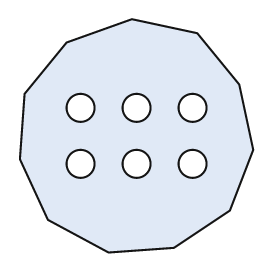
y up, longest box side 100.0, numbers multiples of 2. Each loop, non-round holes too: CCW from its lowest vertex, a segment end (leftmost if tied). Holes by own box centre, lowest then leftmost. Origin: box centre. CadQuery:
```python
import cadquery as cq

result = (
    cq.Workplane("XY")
    .moveTo(-12.0, -50.0)
    .lineTo(16.0, -48.0)
    .lineTo(40.0, -32.0)
    .lineTo(50.0, -6.0)
    .lineTo(44.0, 22.0)
    .lineTo(26.0, 44.0)
    .lineTo(-2.0, 50.0)
    .lineTo(-30.0, 40.0)
    .lineTo(-48.0, 18.0)
    .lineTo(-50.0, -10.0)
    .lineTo(-38.0, -36.0)
    .close()
    .moveTo(-24.0, -12.0)
    .circle(6.0)
    .moveTo(0.0, -12.0)
    .circle(6.0)
    .moveTo(24.0, -12.0)
    .circle(6.0)
    .moveTo(-24.0, 12.0)
    .circle(6.0)
    .moveTo(0.0, 12.0)
    .circle(6.0)
    .moveTo(24.0, 12.0)
    .circle(6.0)
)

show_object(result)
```